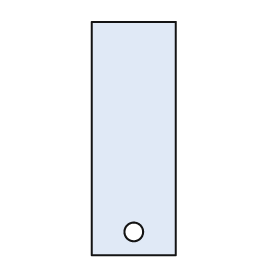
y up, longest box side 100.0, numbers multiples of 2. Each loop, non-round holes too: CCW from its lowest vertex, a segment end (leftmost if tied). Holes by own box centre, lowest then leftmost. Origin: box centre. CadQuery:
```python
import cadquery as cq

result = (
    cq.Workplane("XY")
    .moveTo(-18.0, -50.0)
    .lineTo(18.0, -50.0)
    .lineTo(18.0, 50.0)
    .lineTo(-18.0, 50.0)
    .close()
    .moveTo(0.0, -40.0)
    .circle(4.0)
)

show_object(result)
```